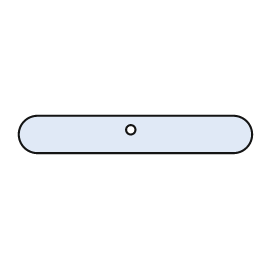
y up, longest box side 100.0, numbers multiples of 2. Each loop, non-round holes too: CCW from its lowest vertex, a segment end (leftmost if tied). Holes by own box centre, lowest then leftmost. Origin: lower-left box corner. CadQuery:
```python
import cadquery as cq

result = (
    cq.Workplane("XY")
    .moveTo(8.0, 0.0)
    .lineTo(92.0, 0.0)
    .threePointArc((100.0, 8.0), (92.0, 16.0))
    .lineTo(8.0, 16.0)
    .threePointArc((0.0, 8.0), (8.0, 0.0))
    .close()
    .moveTo(48.0, 10.0)
    .circle(2.0)
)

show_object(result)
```